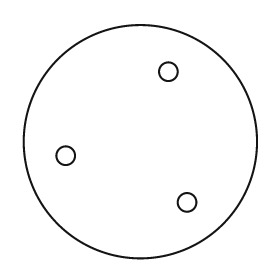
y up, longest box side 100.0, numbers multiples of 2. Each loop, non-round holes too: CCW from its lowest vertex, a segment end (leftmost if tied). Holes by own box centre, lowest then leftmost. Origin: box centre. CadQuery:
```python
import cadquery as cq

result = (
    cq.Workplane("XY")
    .moveTo(0.0, 0.0)
    .circle(50.0)
    .moveTo(20.0, -26.0)
    .circle(4.0)
    .moveTo(-32.0, -6.0)
    .circle(4.0)
    .moveTo(12.0, 30.0)
    .circle(4.0)
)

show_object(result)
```